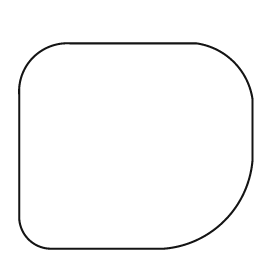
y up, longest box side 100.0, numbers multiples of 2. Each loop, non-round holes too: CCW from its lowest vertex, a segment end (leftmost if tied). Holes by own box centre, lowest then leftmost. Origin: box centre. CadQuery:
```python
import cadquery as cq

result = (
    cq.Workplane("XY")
    .moveTo(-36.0, -44.0)
    .lineTo(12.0, -44.0)
    .threePointArc((38.0, -32.0), (50.0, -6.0))
    .lineTo(50.0, 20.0)
    .threePointArc((42.0, 36.0), (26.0, 44.0))
    .lineTo(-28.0, 44.0)
    .threePointArc((-44.0, 38.0), (-50.0, 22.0))
    .lineTo(-50.0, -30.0)
    .threePointArc((-46.0, -40.0), (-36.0, -44.0))
    .close()
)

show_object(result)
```